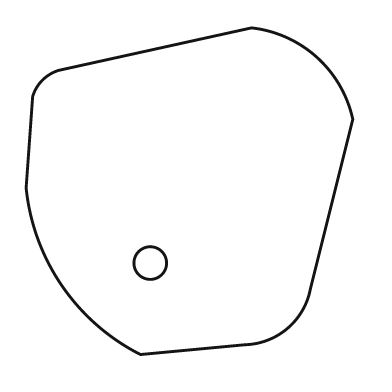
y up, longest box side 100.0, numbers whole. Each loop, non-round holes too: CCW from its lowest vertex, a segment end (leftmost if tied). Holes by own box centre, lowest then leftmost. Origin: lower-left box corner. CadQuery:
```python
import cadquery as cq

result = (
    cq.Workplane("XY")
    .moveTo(35.0, 0.0)
    .lineTo(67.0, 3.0)
    .threePointArc((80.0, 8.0), (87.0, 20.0))
    .lineTo(100.0, 72.0)
    .threePointArc((89.0, 91.0), (69.0, 100.0))
    .lineTo(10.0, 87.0)
    .threePointArc((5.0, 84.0), (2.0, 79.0))
    .lineTo(0.0, 51.0)
    .threePointArc((11.0, 21.0), (35.0, 0.0))
    .close()
    .moveTo(38.0, 28.0)
    .circle(5.0)
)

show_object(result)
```